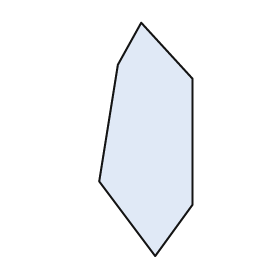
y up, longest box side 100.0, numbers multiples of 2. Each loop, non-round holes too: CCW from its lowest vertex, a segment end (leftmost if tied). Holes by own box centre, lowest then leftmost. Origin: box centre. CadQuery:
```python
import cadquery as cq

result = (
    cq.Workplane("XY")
    .moveTo(4.0, -50.0)
    .lineTo(20.0, -28.0)
    .lineTo(20.0, 26.0)
    .lineTo(-2.0, 50.0)
    .lineTo(-12.0, 32.0)
    .lineTo(-20.0, -18.0)
    .close()
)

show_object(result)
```